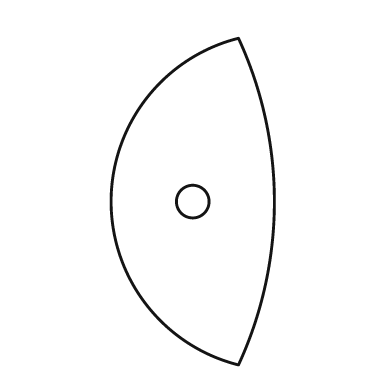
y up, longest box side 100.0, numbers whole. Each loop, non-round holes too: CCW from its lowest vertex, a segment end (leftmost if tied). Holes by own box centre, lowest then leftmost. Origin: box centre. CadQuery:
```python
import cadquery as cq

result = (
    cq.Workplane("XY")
    .moveTo(14.0, -50.0)
    .threePointArc((25.0, 0.0), (14.0, 50.0))
    .threePointArc((-25.0, 0.0), (14.0, -50.0))
    .close()
    .moveTo(0.0, 0.0)
    .circle(5.0)
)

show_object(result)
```